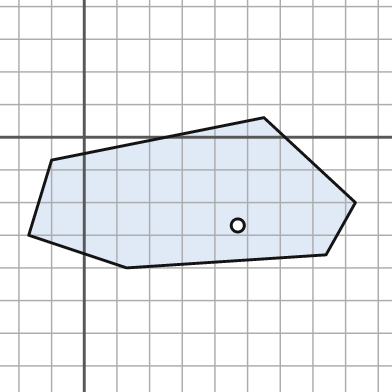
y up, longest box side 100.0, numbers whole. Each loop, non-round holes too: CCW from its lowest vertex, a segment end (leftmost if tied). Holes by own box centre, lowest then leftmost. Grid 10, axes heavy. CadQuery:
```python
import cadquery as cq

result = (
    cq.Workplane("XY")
    .moveTo(13.0, -40.0)
    .lineTo(74.0, -36.0)
    .lineTo(83.0, -20.0)
    .lineTo(55.0, 6.0)
    .lineTo(-10.0, -7.0)
    .lineTo(-17.0, -30.0)
    .close()
    .moveTo(47.0, -27.0)
    .circle(2.0)
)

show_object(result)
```